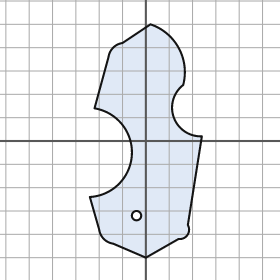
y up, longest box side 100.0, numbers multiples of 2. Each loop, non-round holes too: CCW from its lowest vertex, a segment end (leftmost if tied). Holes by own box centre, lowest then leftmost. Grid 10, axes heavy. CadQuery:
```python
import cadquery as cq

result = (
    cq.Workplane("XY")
    .moveTo(0.0, -50.0)
    .lineTo(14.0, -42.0)
    .threePointArc((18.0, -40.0), (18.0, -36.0))
    .lineTo(24.0, 2.0)
    .threePointArc((12.0, 10.0), (16.0, 24.0))
    .threePointArc((14.0, 40.0), (2.0, 50.0))
    .lineTo(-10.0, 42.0)
    .threePointArc((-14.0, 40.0), (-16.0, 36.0))
    .lineTo(-22.0, 14.0)
    .threePointArc((-6.0, -6.0), (-24.0, -24.0))
    .lineTo(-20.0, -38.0)
    .threePointArc((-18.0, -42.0), (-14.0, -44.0))
    .close()
    .moveTo(-4.0, -32.0)
    .circle(2.0)
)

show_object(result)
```